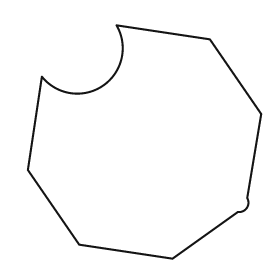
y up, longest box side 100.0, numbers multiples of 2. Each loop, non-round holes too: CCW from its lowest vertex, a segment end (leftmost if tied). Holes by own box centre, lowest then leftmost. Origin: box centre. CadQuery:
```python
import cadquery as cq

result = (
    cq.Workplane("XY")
    .moveTo(12.0, -50.0)
    .lineTo(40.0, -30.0)
    .threePointArc((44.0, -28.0), (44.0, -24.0))
    .lineTo(50.0, 12.0)
    .lineTo(28.0, 44.0)
    .lineTo(-12.0, 50.0)
    .threePointArc((-18.0, 24.0), (-44.0, 28.0))
    .lineTo(-50.0, -12.0)
    .lineTo(-28.0, -44.0)
    .close()
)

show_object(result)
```